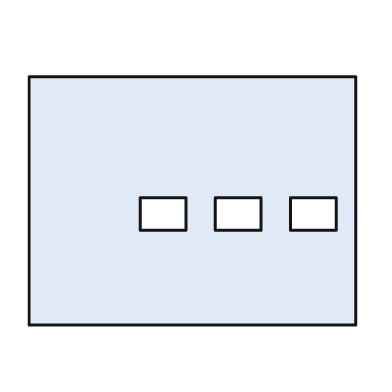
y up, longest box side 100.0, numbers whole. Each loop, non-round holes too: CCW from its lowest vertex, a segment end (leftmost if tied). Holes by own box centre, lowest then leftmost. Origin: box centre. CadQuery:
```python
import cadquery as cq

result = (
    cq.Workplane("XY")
    .moveTo(-50.0, -38.0)
    .lineTo(50.0, -38.0)
    .lineTo(50.0, 38.0)
    .lineTo(-50.0, 38.0)
    .close()
    .moveTo(-16.0, -9.0)
    .lineTo(-2.0, -9.0)
    .lineTo(-2.0, 1.0)
    .lineTo(-16.0, 1.0)
    .close()
    .moveTo(7.0, -9.0)
    .lineTo(21.0, -9.0)
    .lineTo(21.0, 1.0)
    .lineTo(7.0, 1.0)
    .close()
    .moveTo(30.0, -9.0)
    .lineTo(44.0, -9.0)
    .lineTo(44.0, 1.0)
    .lineTo(30.0, 1.0)
    .close()
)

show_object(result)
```